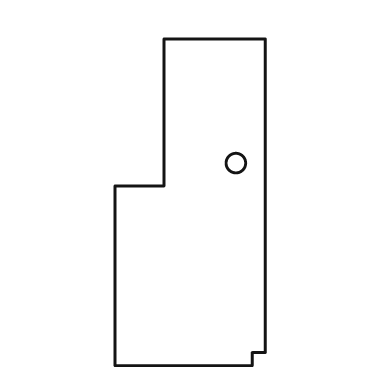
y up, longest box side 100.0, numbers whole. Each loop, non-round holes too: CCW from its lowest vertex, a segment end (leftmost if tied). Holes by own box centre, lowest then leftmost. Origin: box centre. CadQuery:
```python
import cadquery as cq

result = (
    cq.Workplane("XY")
    .moveTo(-23.0, -50.0)
    .lineTo(19.0, -50.0)
    .lineTo(19.0, -46.0)
    .lineTo(23.0, -46.0)
    .lineTo(23.0, 50.0)
    .lineTo(-8.0, 50.0)
    .lineTo(-8.0, 5.0)
    .lineTo(-23.0, 5.0)
    .close()
    .moveTo(14.0, 12.0)
    .circle(3.0)
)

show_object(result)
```